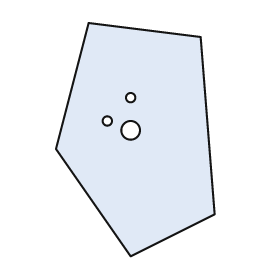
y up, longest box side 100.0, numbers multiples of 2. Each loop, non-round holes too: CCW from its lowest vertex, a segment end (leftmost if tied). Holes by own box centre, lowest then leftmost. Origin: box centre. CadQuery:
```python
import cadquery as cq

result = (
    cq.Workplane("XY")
    .moveTo(-2.0, -50.0)
    .lineTo(34.0, -32.0)
    .lineTo(28.0, 44.0)
    .lineTo(-20.0, 50.0)
    .lineTo(-34.0, -4.0)
    .close()
    .moveTo(-2.0, 4.0)
    .circle(4.0)
    .moveTo(-12.0, 8.0)
    .circle(2.0)
    .moveTo(-2.0, 18.0)
    .circle(2.0)
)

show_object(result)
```